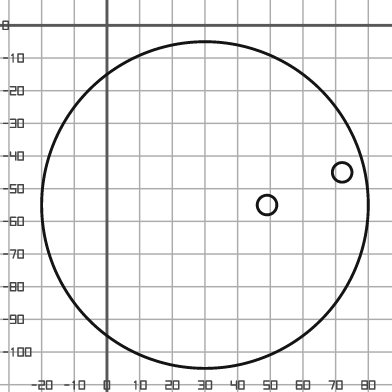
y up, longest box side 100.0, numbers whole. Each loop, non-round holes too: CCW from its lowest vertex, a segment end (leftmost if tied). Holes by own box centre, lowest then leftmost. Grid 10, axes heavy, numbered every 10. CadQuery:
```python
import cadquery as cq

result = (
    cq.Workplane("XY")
    .moveTo(30.0, -55.0)
    .circle(50.0)
    .moveTo(49.0, -55.0)
    .circle(3.0)
    .moveTo(72.0, -45.0)
    .circle(3.0)
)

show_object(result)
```